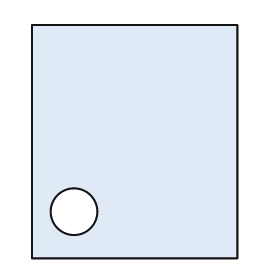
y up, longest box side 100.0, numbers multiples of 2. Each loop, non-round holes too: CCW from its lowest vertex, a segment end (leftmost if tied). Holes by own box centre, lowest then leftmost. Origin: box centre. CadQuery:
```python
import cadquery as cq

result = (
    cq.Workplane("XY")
    .moveTo(-44.0, -50.0)
    .lineTo(44.0, -50.0)
    .lineTo(44.0, 50.0)
    .lineTo(-44.0, 50.0)
    .close()
    .moveTo(-26.0, -30.0)
    .circle(10.0)
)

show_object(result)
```